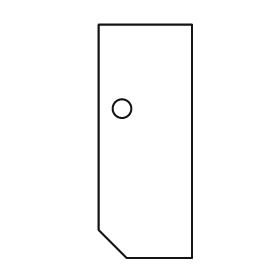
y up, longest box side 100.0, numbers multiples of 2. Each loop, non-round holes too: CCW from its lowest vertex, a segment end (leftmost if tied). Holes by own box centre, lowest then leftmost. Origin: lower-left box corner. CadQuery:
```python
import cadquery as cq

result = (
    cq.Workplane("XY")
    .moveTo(12.0, 0.0)
    .lineTo(40.0, 0.0)
    .lineTo(40.0, 100.0)
    .lineTo(0.0, 100.0)
    .lineTo(0.0, 12.0)
    .close()
    .moveTo(10.0, 64.0)
    .circle(4.0)
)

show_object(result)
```